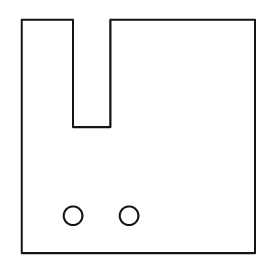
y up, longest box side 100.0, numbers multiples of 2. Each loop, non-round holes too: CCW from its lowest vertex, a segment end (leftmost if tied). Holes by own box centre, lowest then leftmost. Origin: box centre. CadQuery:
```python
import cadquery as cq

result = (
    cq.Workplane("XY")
    .moveTo(-50.0, -50.0)
    .lineTo(50.0, -50.0)
    .lineTo(50.0, 50.0)
    .lineTo(-12.0, 50.0)
    .lineTo(-12.0, 4.0)
    .lineTo(-28.0, 4.0)
    .lineTo(-28.0, 50.0)
    .lineTo(-50.0, 50.0)
    .close()
    .moveTo(-28.0, -34.0)
    .circle(4.0)
    .moveTo(-4.0, -34.0)
    .circle(4.0)
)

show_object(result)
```